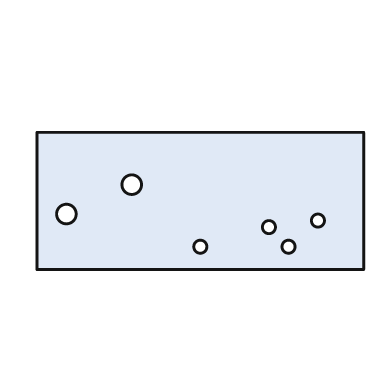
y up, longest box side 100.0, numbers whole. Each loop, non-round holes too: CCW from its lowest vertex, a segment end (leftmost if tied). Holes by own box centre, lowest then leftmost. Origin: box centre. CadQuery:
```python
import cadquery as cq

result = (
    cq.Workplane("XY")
    .moveTo(-50.0, -21.0)
    .lineTo(50.0, -21.0)
    .lineTo(50.0, 21.0)
    .lineTo(-50.0, 21.0)
    .close()
    .moveTo(0.0, -14.0)
    .circle(2.0)
    .moveTo(27.0, -14.0)
    .circle(2.0)
    .moveTo(21.0, -8.0)
    .circle(2.0)
    .moveTo(36.0, -6.0)
    .circle(2.0)
    .moveTo(-41.0, -4.0)
    .circle(3.0)
    .moveTo(-21.0, 5.0)
    .circle(3.0)
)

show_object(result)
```